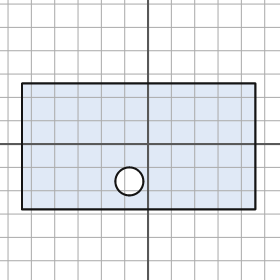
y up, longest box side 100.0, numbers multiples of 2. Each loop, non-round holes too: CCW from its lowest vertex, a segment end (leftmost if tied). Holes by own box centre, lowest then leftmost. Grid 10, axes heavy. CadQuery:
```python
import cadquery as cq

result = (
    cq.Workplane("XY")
    .moveTo(-54.0, -28.0)
    .lineTo(46.0, -28.0)
    .lineTo(46.0, 26.0)
    .lineTo(-54.0, 26.0)
    .close()
    .moveTo(-8.0, -16.0)
    .circle(6.0)
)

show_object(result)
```